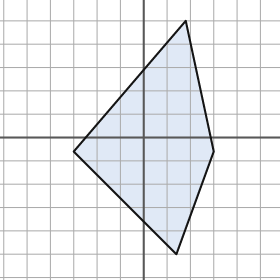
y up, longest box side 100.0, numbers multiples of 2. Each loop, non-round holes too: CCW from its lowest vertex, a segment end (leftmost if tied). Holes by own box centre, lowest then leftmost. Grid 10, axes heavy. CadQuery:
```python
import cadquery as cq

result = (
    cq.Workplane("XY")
    .moveTo(14.0, -50.0)
    .lineTo(30.0, -6.0)
    .lineTo(18.0, 50.0)
    .lineTo(-30.0, -6.0)
    .close()
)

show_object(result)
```